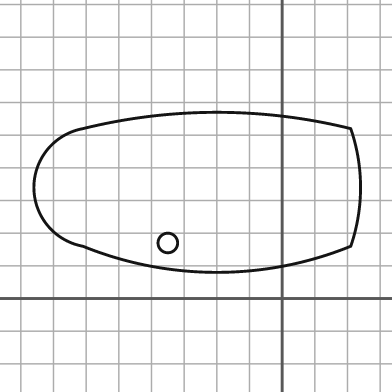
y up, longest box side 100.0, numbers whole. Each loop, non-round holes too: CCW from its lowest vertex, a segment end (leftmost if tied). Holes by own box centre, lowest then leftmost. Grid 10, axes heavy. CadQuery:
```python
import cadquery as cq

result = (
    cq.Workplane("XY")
    .moveTo(-61.0, 16.0)
    .threePointArc((-20.0, 8.0), (21.0, 16.0))
    .threePointArc((24.0, 34.0), (21.0, 52.0))
    .threePointArc((-20.0, 57.0), (-61.0, 52.0))
    .threePointArc((-76.0, 34.0), (-61.0, 16.0))
    .close()
    .moveTo(-35.0, 17.0)
    .circle(3.0)
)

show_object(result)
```